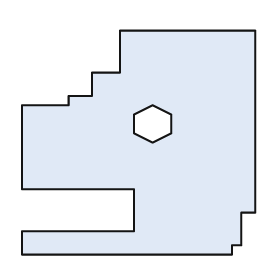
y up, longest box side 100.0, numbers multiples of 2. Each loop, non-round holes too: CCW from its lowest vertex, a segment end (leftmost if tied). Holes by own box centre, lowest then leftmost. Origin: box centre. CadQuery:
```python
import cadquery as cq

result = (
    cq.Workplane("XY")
    .moveTo(-50.0, -48.0)
    .lineTo(40.0, -48.0)
    .lineTo(40.0, -44.0)
    .lineTo(44.0, -44.0)
    .lineTo(44.0, -30.0)
    .lineTo(50.0, -30.0)
    .lineTo(50.0, 48.0)
    .lineTo(-8.0, 48.0)
    .lineTo(-8.0, 30.0)
    .lineTo(-20.0, 30.0)
    .lineTo(-20.0, 20.0)
    .lineTo(-30.0, 20.0)
    .lineTo(-30.0, 16.0)
    .lineTo(-50.0, 16.0)
    .lineTo(-50.0, -20.0)
    .lineTo(-2.0, -20.0)
    .lineTo(-2.0, -38.0)
    .lineTo(-50.0, -38.0)
    .close()
    .moveTo(6.0, 0.0)
    .lineTo(14.0, 4.0)
    .lineTo(14.0, 12.0)
    .lineTo(6.0, 16.0)
    .lineTo(-2.0, 12.0)
    .lineTo(-2.0, 4.0)
    .close()
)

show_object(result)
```